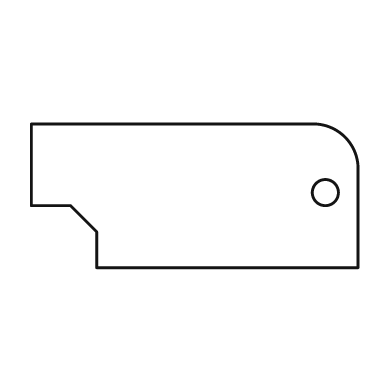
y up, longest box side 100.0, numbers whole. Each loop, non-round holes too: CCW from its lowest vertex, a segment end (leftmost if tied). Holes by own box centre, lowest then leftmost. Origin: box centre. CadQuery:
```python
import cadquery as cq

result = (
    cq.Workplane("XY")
    .moveTo(-30.0, -22.0)
    .lineTo(50.0, -22.0)
    .lineTo(50.0, 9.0)
    .threePointArc((46.0, 18.0), (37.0, 22.0))
    .lineTo(-50.0, 22.0)
    .lineTo(-50.0, -3.0)
    .lineTo(-38.0, -3.0)
    .lineTo(-30.0, -11.0)
    .close()
    .moveTo(40.0, 1.0)
    .circle(4.0)
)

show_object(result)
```